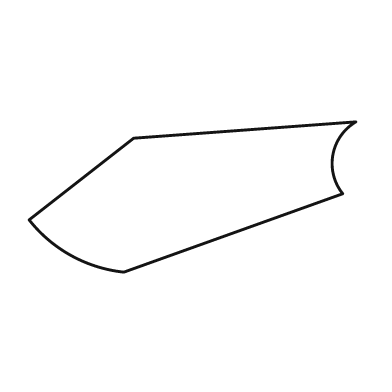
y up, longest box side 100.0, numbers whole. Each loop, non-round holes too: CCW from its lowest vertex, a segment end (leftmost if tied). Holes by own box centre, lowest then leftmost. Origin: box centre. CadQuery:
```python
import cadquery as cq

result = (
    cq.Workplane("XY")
    .moveTo(-21.0, -23.0)
    .lineTo(46.0, 1.0)
    .threePointArc((43.0, 13.0), (50.0, 23.0))
    .lineTo(-18.0, 18.0)
    .lineTo(-50.0, -7.0)
    .threePointArc((-37.0, -18.0), (-21.0, -23.0))
    .close()
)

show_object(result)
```